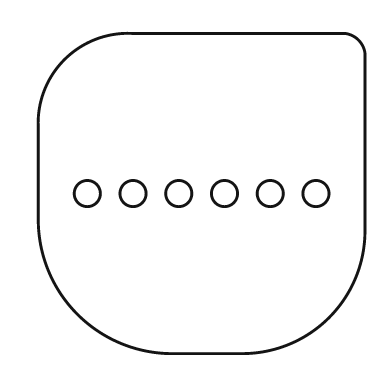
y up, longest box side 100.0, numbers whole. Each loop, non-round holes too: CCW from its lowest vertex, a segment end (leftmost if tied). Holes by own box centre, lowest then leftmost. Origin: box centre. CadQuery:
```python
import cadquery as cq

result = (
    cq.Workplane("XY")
    .moveTo(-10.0, -49.0)
    .lineTo(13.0, -49.0)
    .threePointArc((39.0, -38.0), (50.0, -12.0))
    .lineTo(50.0, 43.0)
    .threePointArc((48.0, 47.0), (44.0, 49.0))
    .lineTo(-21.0, 49.0)
    .threePointArc((-42.0, 41.0), (-50.0, 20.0))
    .lineTo(-50.0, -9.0)
    .threePointArc((-38.0, -37.0), (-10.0, -49.0))
    .close()
    .moveTo(-35.0, 0.0)
    .circle(4.0)
    .moveTo(-21.0, 0.0)
    .circle(4.0)
    .moveTo(-7.0, 0.0)
    .circle(4.0)
    .moveTo(7.0, 0.0)
    .circle(4.0)
    .moveTo(21.0, 0.0)
    .circle(4.0)
    .moveTo(35.0, 0.0)
    .circle(4.0)
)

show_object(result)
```